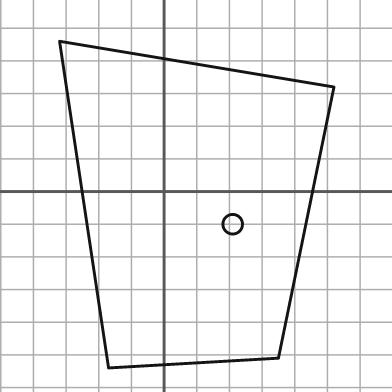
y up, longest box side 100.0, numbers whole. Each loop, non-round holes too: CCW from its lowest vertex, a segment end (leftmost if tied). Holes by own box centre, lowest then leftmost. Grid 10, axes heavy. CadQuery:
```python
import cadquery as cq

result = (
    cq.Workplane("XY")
    .moveTo(-17.0, -54.0)
    .lineTo(35.0, -51.0)
    .lineTo(52.0, 32.0)
    .lineTo(-32.0, 46.0)
    .close()
    .moveTo(21.0, -10.0)
    .circle(3.0)
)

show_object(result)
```